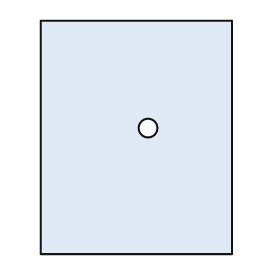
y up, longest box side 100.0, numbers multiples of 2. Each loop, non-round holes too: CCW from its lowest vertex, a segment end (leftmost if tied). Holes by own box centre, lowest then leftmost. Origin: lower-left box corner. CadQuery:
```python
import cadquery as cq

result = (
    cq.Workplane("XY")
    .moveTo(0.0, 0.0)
    .lineTo(82.0, 0.0)
    .lineTo(82.0, 100.0)
    .lineTo(0.0, 100.0)
    .close()
    .moveTo(46.0, 54.0)
    .circle(4.0)
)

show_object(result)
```